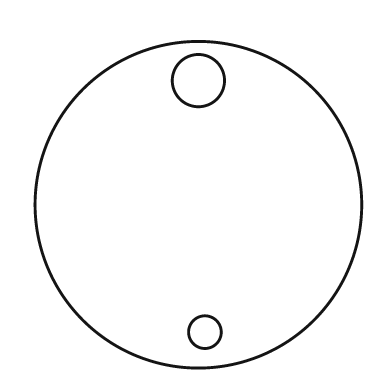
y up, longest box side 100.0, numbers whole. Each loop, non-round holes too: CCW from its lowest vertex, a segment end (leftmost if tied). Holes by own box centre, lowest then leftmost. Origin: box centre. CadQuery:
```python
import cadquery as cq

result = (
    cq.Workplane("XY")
    .moveTo(0.0, 0.0)
    .circle(50.0)
    .moveTo(2.0, -39.0)
    .circle(5.0)
    .moveTo(0.0, 38.0)
    .circle(8.0)
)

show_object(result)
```